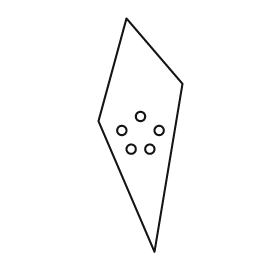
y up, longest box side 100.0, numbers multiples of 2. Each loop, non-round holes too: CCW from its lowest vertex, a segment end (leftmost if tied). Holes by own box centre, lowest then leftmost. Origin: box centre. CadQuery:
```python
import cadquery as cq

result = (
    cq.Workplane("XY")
    .moveTo(6.0, -50.0)
    .lineTo(18.0, 22.0)
    .lineTo(-6.0, 50.0)
    .lineTo(-18.0, 6.0)
    .close()
    .moveTo(-4.0, -6.0)
    .circle(2.0)
    .moveTo(4.0, -6.0)
    .circle(2.0)
    .moveTo(-8.0, 2.0)
    .circle(2.0)
    .moveTo(8.0, 2.0)
    .circle(2.0)
    .moveTo(0.0, 8.0)
    .circle(2.0)
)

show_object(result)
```